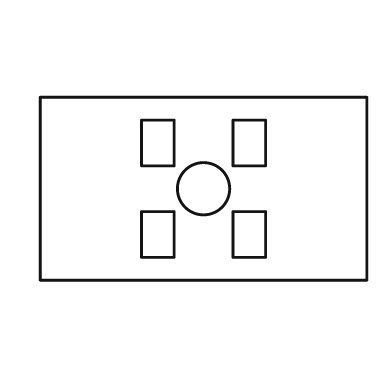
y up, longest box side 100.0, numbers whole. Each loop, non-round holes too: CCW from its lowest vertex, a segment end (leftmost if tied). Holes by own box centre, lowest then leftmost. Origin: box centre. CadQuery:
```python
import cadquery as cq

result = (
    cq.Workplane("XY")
    .moveTo(-50.0, -28.0)
    .lineTo(50.0, -28.0)
    .lineTo(50.0, 28.0)
    .lineTo(-50.0, 28.0)
    .close()
    .moveTo(-19.0, -21.0)
    .lineTo(-9.0, -21.0)
    .lineTo(-9.0, -7.0)
    .lineTo(-19.0, -7.0)
    .close()
    .moveTo(9.0, -21.0)
    .lineTo(19.0, -21.0)
    .lineTo(19.0, -7.0)
    .lineTo(9.0, -7.0)
    .close()
    .moveTo(0.0, 0.0)
    .circle(8.0)
    .moveTo(-19.0, 7.0)
    .lineTo(-9.0, 7.0)
    .lineTo(-9.0, 21.0)
    .lineTo(-19.0, 21.0)
    .close()
    .moveTo(9.0, 7.0)
    .lineTo(19.0, 7.0)
    .lineTo(19.0, 21.0)
    .lineTo(9.0, 21.0)
    .close()
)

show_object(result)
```